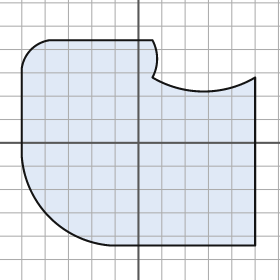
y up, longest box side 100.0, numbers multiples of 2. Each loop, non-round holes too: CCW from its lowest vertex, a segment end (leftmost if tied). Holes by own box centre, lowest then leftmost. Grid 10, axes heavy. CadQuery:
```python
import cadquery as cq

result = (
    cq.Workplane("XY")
    .moveTo(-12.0, -44.0)
    .lineTo(50.0, -44.0)
    .lineTo(50.0, 28.0)
    .threePointArc((28.0, 22.0), (6.0, 28.0))
    .threePointArc((8.0, 36.0), (6.0, 44.0))
    .lineTo(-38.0, 44.0)
    .threePointArc((-46.0, 40.0), (-50.0, 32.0))
    .lineTo(-50.0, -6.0)
    .threePointArc((-38.0, -32.0), (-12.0, -44.0))
    .close()
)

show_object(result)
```